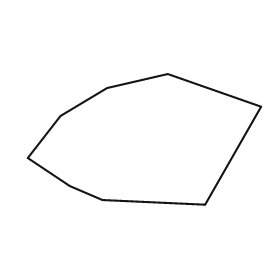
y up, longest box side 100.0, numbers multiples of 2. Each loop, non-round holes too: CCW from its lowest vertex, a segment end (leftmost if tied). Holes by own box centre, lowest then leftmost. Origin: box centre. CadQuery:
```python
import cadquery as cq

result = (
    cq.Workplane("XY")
    .moveTo(26.0, -28.0)
    .lineTo(50.0, 14.0)
    .lineTo(10.0, 28.0)
    .lineTo(-16.0, 22.0)
    .lineTo(-36.0, 10.0)
    .lineTo(-50.0, -8.0)
    .lineTo(-32.0, -20.0)
    .lineTo(-18.0, -26.0)
    .close()
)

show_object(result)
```